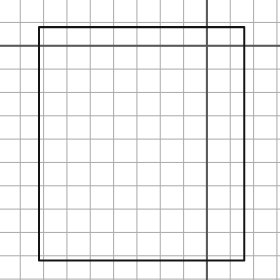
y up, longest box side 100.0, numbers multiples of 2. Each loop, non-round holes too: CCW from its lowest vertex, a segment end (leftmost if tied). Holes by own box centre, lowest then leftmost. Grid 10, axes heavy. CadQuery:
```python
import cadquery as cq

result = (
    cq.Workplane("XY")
    .moveTo(-72.0, -92.0)
    .lineTo(16.0, -92.0)
    .lineTo(16.0, 8.0)
    .lineTo(-72.0, 8.0)
    .close()
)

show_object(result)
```